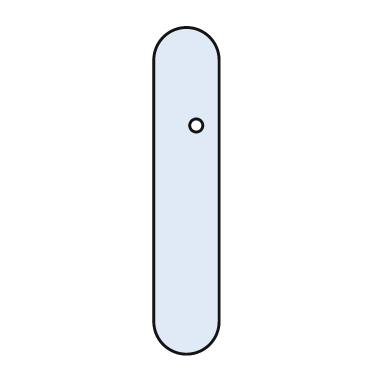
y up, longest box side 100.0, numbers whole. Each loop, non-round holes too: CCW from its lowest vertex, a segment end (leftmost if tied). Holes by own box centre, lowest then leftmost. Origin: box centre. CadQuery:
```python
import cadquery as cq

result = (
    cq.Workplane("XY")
    .moveTo(-10.0, -40.0)
    .threePointArc((0.0, -50.0), (10.0, -40.0))
    .lineTo(10.0, 40.0)
    .threePointArc((0.0, 50.0), (-10.0, 40.0))
    .close()
    .moveTo(3.0, 20.0)
    .circle(2.0)
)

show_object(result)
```